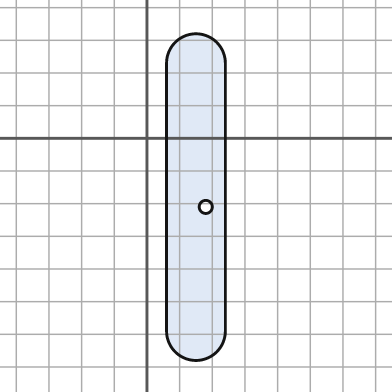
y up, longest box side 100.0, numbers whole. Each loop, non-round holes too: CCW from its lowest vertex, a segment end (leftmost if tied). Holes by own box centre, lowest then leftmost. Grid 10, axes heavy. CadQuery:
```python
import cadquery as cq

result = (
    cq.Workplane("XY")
    .moveTo(6.0, -59.0)
    .threePointArc((15.0, -68.0), (24.0, -59.0))
    .lineTo(24.0, 23.0)
    .threePointArc((15.0, 32.0), (6.0, 23.0))
    .close()
    .moveTo(18.0, -21.0)
    .circle(2.0)
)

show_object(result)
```